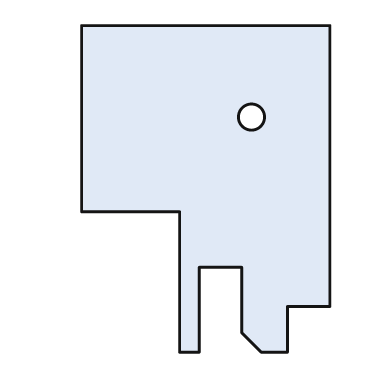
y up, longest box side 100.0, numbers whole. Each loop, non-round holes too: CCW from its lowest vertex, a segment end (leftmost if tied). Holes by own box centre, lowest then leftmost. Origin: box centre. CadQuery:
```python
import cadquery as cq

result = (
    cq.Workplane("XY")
    .moveTo(-8.0, -50.0)
    .lineTo(-2.0, -50.0)
    .lineTo(-2.0, -24.0)
    .lineTo(11.0, -24.0)
    .lineTo(11.0, -44.0)
    .lineTo(17.0, -50.0)
    .lineTo(25.0, -50.0)
    .lineTo(25.0, -36.0)
    .lineTo(38.0, -36.0)
    .lineTo(38.0, 50.0)
    .lineTo(-38.0, 50.0)
    .lineTo(-38.0, -7.0)
    .lineTo(-8.0, -7.0)
    .close()
    .moveTo(14.0, 22.0)
    .circle(4.0)
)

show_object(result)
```